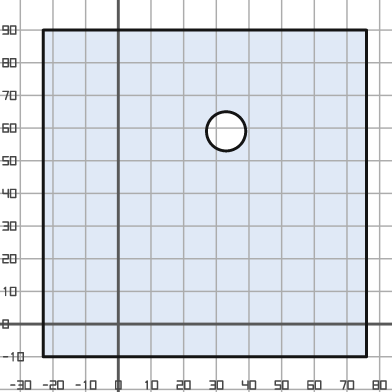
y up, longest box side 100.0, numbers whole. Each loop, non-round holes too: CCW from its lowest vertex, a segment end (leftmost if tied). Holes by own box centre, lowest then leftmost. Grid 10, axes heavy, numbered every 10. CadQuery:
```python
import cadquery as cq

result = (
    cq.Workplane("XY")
    .moveTo(-23.0, -10.0)
    .lineTo(76.0, -10.0)
    .lineTo(76.0, 90.0)
    .lineTo(-23.0, 90.0)
    .close()
    .moveTo(33.0, 59.0)
    .circle(6.0)
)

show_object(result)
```